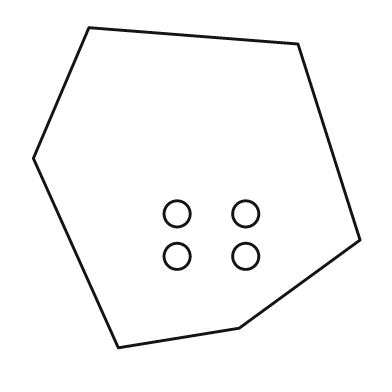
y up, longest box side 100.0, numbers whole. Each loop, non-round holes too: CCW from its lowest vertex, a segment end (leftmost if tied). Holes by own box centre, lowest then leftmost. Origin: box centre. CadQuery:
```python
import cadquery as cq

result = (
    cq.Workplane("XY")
    .moveTo(-24.0, -49.0)
    .lineTo(13.0, -43.0)
    .lineTo(50.0, -16.0)
    .lineTo(31.0, 44.0)
    .lineTo(-33.0, 49.0)
    .lineTo(-50.0, 9.0)
    .close()
    .moveTo(-6.0, -21.0)
    .circle(4.0)
    .moveTo(15.0, -21.0)
    .circle(4.0)
    .moveTo(-6.0, -8.0)
    .circle(4.0)
    .moveTo(15.0, -8.0)
    .circle(4.0)
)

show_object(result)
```